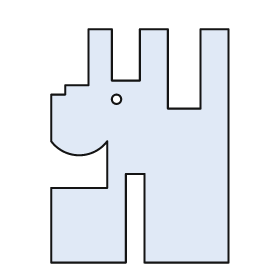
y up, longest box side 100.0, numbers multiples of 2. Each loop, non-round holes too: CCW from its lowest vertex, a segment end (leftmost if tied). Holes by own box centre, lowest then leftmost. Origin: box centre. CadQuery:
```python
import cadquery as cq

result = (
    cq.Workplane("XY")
    .moveTo(-38.0, -50.0)
    .lineTo(-6.0, -50.0)
    .lineTo(-6.0, -12.0)
    .lineTo(2.0, -12.0)
    .lineTo(2.0, -50.0)
    .lineTo(38.0, -50.0)
    .lineTo(38.0, 50.0)
    .lineTo(26.0, 50.0)
    .lineTo(26.0, 16.0)
    .lineTo(12.0, 16.0)
    .lineTo(12.0, 50.0)
    .lineTo(0.0, 50.0)
    .lineTo(0.0, 28.0)
    .lineTo(-12.0, 28.0)
    .lineTo(-12.0, 50.0)
    .lineTo(-22.0, 50.0)
    .lineTo(-22.0, 26.0)
    .lineTo(-32.0, 26.0)
    .lineTo(-32.0, 22.0)
    .lineTo(-38.0, 22.0)
    .lineTo(-38.0, 2.0)
    .threePointArc((-26.0, -4.0), (-14.0, 2.0))
    .lineTo(-14.0, -18.0)
    .lineTo(-38.0, -18.0)
    .close()
    .moveTo(-10.0, 20.0)
    .circle(2.0)
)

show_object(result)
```